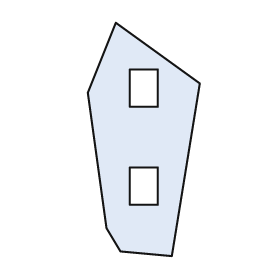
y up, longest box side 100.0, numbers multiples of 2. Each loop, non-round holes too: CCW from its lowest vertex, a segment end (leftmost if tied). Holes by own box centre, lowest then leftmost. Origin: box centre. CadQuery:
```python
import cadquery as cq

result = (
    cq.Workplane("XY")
    .moveTo(12.0, -50.0)
    .lineTo(24.0, 24.0)
    .lineTo(-12.0, 50.0)
    .lineTo(-24.0, 20.0)
    .lineTo(-16.0, -38.0)
    .lineTo(-10.0, -48.0)
    .close()
    .moveTo(-6.0, -28.0)
    .lineTo(6.0, -28.0)
    .lineTo(6.0, -12.0)
    .lineTo(-6.0, -12.0)
    .close()
    .moveTo(-6.0, 14.0)
    .lineTo(6.0, 14.0)
    .lineTo(6.0, 30.0)
    .lineTo(-6.0, 30.0)
    .close()
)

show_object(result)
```